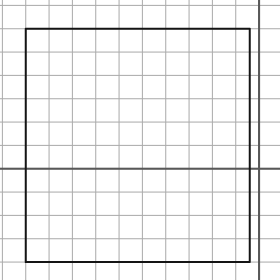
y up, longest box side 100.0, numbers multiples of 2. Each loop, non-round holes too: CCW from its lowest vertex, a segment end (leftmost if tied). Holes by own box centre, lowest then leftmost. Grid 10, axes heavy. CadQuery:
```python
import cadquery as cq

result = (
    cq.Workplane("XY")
    .moveTo(-100.0, -40.0)
    .lineTo(-4.0, -40.0)
    .lineTo(-4.0, 60.0)
    .lineTo(-100.0, 60.0)
    .close()
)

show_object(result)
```